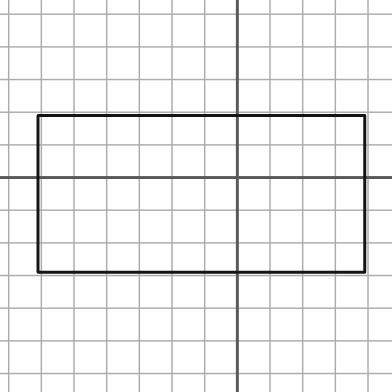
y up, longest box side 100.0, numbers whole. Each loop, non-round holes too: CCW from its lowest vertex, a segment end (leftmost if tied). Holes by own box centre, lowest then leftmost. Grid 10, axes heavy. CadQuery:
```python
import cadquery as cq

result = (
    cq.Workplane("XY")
    .moveTo(-61.0, -29.0)
    .lineTo(39.0, -29.0)
    .lineTo(39.0, 19.0)
    .lineTo(-61.0, 19.0)
    .close()
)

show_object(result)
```